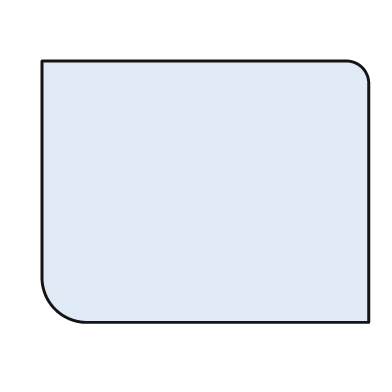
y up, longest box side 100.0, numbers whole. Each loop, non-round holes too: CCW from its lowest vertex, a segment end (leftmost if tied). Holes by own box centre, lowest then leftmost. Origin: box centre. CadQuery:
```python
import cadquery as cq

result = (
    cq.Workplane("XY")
    .moveTo(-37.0, -40.0)
    .lineTo(50.0, -40.0)
    .lineTo(50.0, 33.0)
    .threePointArc((48.0, 38.0), (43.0, 40.0))
    .lineTo(-50.0, 40.0)
    .lineTo(-50.0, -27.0)
    .threePointArc((-46.0, -36.0), (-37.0, -40.0))
    .close()
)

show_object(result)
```